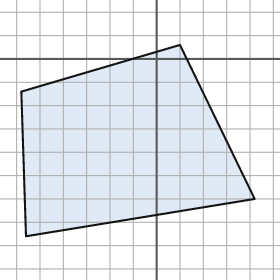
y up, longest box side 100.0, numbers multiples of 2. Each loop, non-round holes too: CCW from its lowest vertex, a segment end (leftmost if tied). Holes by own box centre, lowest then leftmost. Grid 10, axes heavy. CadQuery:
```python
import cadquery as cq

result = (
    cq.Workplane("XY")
    .moveTo(-56.0, -76.0)
    .lineTo(42.0, -60.0)
    .lineTo(10.0, 6.0)
    .lineTo(-58.0, -14.0)
    .close()
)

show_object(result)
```